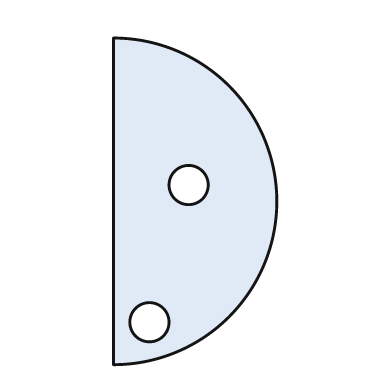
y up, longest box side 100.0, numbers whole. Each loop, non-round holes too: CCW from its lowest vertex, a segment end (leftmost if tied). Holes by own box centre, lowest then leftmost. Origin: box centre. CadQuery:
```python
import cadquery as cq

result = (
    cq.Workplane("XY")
    .moveTo(-25.0, -50.0)
    .threePointArc((25.0, 0.0), (-25.0, 50.0))
    .close()
    .moveTo(-14.0, -37.0)
    .circle(6.0)
    .moveTo(-2.0, 5.0)
    .circle(6.0)
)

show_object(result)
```